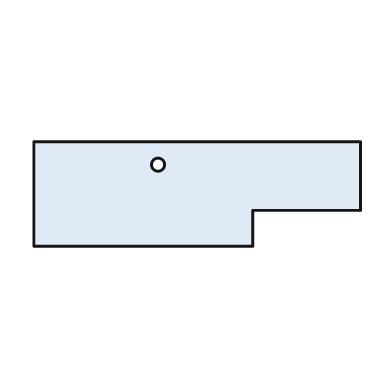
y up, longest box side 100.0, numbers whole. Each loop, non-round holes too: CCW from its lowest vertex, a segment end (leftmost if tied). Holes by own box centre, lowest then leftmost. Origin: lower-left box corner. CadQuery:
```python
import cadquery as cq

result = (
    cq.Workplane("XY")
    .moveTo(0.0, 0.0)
    .lineTo(67.0, 0.0)
    .lineTo(67.0, 11.0)
    .lineTo(100.0, 11.0)
    .lineTo(100.0, 32.0)
    .lineTo(0.0, 32.0)
    .close()
    .moveTo(38.0, 25.0)
    .circle(2.0)
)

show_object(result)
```